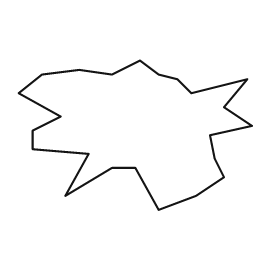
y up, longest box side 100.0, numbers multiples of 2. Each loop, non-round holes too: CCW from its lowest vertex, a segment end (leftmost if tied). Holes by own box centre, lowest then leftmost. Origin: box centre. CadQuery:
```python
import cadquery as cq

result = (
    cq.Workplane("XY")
    .moveTo(10.0, -32.0)
    .lineTo(26.0, -26.0)
    .lineTo(38.0, -18.0)
    .lineTo(34.0, -10.0)
    .lineTo(32.0, 0.0)
    .lineTo(50.0, 4.0)
    .lineTo(38.0, 12.0)
    .lineTo(48.0, 24.0)
    .lineTo(24.0, 18.0)
    .lineTo(18.0, 24.0)
    .lineTo(10.0, 26.0)
    .lineTo(2.0, 32.0)
    .lineTo(-10.0, 26.0)
    .lineTo(-24.0, 28.0)
    .lineTo(-40.0, 26.0)
    .lineTo(-50.0, 18.0)
    .lineTo(-32.0, 8.0)
    .lineTo(-44.0, 2.0)
    .lineTo(-44.0, -6.0)
    .lineTo(-20.0, -8.0)
    .lineTo(-30.0, -26.0)
    .lineTo(-10.0, -14.0)
    .lineTo(0.0, -14.0)
    .close()
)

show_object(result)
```